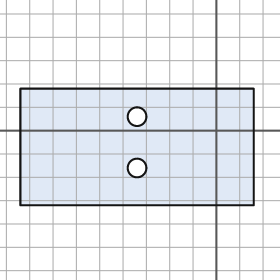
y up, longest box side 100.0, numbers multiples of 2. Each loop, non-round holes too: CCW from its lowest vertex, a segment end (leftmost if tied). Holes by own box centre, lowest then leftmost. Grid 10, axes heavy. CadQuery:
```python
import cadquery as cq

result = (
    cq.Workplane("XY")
    .moveTo(-84.0, -32.0)
    .lineTo(16.0, -32.0)
    .lineTo(16.0, 18.0)
    .lineTo(-84.0, 18.0)
    .close()
    .moveTo(-34.0, -16.0)
    .circle(4.0)
    .moveTo(-34.0, 6.0)
    .circle(4.0)
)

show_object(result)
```